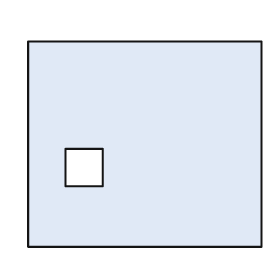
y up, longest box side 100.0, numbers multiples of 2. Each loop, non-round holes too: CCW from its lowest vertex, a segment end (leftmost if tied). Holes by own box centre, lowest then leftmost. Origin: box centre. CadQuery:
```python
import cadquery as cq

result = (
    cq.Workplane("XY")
    .moveTo(-50.0, -44.0)
    .lineTo(50.0, -44.0)
    .lineTo(50.0, 44.0)
    .lineTo(-50.0, 44.0)
    .close()
    .moveTo(-34.0, -18.0)
    .lineTo(-18.0, -18.0)
    .lineTo(-18.0, -2.0)
    .lineTo(-34.0, -2.0)
    .close()
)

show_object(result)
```